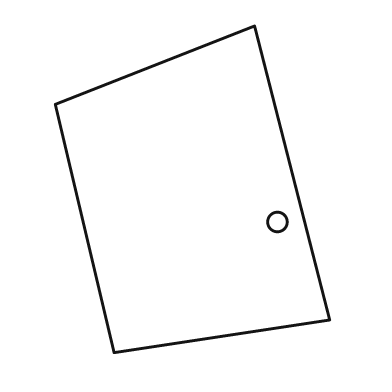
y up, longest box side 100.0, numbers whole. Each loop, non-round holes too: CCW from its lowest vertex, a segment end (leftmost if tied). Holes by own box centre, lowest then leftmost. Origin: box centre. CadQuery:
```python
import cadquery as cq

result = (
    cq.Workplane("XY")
    .moveTo(-24.0, -50.0)
    .lineTo(42.0, -40.0)
    .lineTo(19.0, 50.0)
    .lineTo(-42.0, 26.0)
    .close()
    .moveTo(26.0, -10.0)
    .circle(3.0)
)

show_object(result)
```